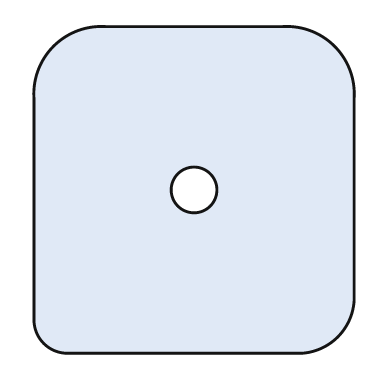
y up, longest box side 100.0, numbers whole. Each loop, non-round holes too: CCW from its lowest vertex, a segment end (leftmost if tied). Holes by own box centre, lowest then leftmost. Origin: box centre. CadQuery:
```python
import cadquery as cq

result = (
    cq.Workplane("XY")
    .moveTo(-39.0, -50.0)
    .lineTo(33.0, -50.0)
    .threePointArc((44.0, -45.0), (49.0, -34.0))
    .lineTo(49.0, 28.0)
    .threePointArc((43.0, 44.0), (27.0, 50.0))
    .lineTo(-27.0, 50.0)
    .threePointArc((-43.0, 44.0), (-49.0, 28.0))
    .lineTo(-49.0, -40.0)
    .threePointArc((-46.0, -47.0), (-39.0, -50.0))
    .close()
    .moveTo(0.0, 0.0)
    .circle(7.0)
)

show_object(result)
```